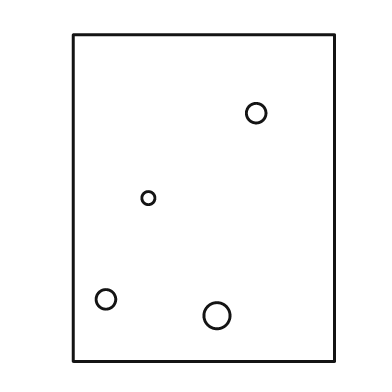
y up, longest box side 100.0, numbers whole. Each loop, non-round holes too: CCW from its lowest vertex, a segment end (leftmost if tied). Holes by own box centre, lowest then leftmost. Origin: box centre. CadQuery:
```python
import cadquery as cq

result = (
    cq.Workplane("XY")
    .moveTo(-40.0, -50.0)
    .lineTo(40.0, -50.0)
    .lineTo(40.0, 50.0)
    .lineTo(-40.0, 50.0)
    .close()
    .moveTo(4.0, -36.0)
    .circle(4.0)
    .moveTo(-30.0, -31.0)
    .circle(3.0)
    .moveTo(-17.0, 0.0)
    .circle(2.0)
    .moveTo(16.0, 26.0)
    .circle(3.0)
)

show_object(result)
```